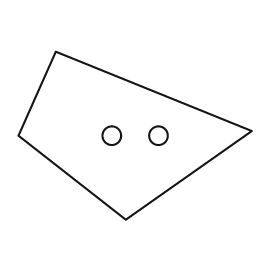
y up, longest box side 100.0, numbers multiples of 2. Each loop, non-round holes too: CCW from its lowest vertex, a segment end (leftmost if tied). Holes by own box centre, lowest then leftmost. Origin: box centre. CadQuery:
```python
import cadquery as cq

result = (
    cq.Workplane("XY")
    .moveTo(-4.0, -36.0)
    .lineTo(50.0, 2.0)
    .lineTo(-34.0, 36.0)
    .lineTo(-50.0, 0.0)
    .close()
    .moveTo(-10.0, 0.0)
    .circle(4.0)
    .moveTo(10.0, 0.0)
    .circle(4.0)
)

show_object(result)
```